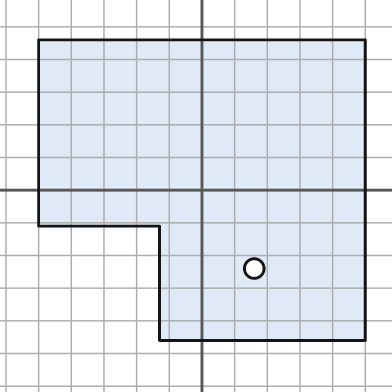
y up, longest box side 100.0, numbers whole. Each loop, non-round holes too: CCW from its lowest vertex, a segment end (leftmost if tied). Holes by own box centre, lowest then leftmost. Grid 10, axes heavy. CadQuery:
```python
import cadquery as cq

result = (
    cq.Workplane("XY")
    .moveTo(-13.0, -46.0)
    .lineTo(50.0, -46.0)
    .lineTo(50.0, 46.0)
    .lineTo(-50.0, 46.0)
    .lineTo(-50.0, -11.0)
    .lineTo(-13.0, -11.0)
    .close()
    .moveTo(16.0, -24.0)
    .circle(3.0)
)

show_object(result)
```